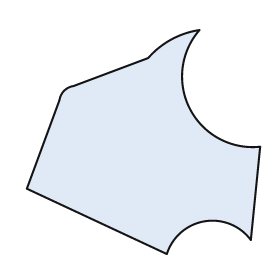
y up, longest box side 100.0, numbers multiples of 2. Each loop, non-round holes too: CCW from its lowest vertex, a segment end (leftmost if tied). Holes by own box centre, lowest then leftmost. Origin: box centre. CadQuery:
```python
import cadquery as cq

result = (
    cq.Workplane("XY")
    .moveTo(10.0, -48.0)
    .threePointArc((26.0, -34.0), (46.0, -42.0))
    .lineTo(50.0, -2.0)
    .threePointArc((20.0, 14.0), (24.0, 48.0))
    .threePointArc((12.0, 44.0), (2.0, 36.0))
    .lineTo(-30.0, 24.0)
    .threePointArc((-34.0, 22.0), (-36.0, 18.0))
    .lineTo(-50.0, -20.0)
    .close()
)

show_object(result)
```